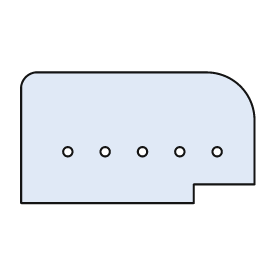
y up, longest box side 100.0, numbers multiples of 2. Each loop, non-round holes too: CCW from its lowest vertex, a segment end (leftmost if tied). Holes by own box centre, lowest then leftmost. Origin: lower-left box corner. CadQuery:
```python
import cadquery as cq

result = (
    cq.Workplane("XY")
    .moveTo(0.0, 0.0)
    .lineTo(74.0, 0.0)
    .lineTo(74.0, 8.0)
    .lineTo(100.0, 8.0)
    .lineTo(100.0, 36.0)
    .threePointArc((94.0, 50.0), (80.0, 56.0))
    .lineTo(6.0, 56.0)
    .threePointArc((2.0, 54.0), (0.0, 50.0))
    .close()
    .moveTo(20.0, 22.0)
    .circle(2.0)
    .moveTo(36.0, 22.0)
    .circle(2.0)
    .moveTo(52.0, 22.0)
    .circle(2.0)
    .moveTo(68.0, 22.0)
    .circle(2.0)
    .moveTo(84.0, 22.0)
    .circle(2.0)
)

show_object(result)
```